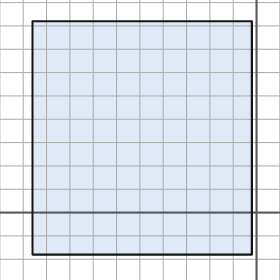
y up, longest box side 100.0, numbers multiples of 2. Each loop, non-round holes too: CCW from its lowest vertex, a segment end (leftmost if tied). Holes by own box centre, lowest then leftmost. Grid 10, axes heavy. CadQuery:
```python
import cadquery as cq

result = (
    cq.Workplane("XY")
    .moveTo(-96.0, -18.0)
    .lineTo(-2.0, -18.0)
    .lineTo(-2.0, 82.0)
    .lineTo(-96.0, 82.0)
    .close()
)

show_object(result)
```